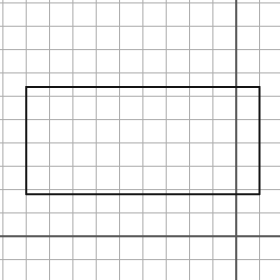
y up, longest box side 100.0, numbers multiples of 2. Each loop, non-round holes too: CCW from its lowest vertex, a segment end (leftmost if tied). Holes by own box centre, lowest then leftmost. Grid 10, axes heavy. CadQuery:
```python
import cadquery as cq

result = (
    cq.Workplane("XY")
    .moveTo(-90.0, 18.0)
    .lineTo(10.0, 18.0)
    .lineTo(10.0, 64.0)
    .lineTo(-90.0, 64.0)
    .close()
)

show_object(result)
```